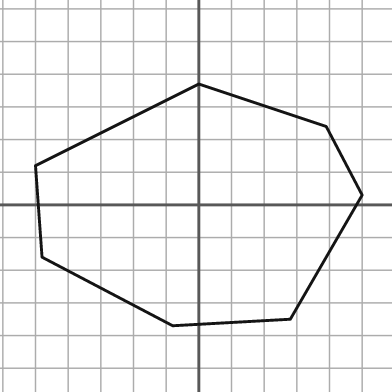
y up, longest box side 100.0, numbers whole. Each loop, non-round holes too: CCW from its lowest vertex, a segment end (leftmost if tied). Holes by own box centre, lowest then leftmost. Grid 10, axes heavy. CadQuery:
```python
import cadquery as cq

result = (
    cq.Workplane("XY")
    .moveTo(-8.0, -37.0)
    .lineTo(28.0, -35.0)
    .lineTo(50.0, 3.0)
    .lineTo(39.0, 24.0)
    .lineTo(0.0, 37.0)
    .lineTo(-50.0, 12.0)
    .lineTo(-48.0, -16.0)
    .close()
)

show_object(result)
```